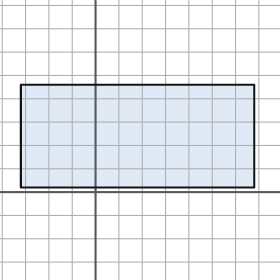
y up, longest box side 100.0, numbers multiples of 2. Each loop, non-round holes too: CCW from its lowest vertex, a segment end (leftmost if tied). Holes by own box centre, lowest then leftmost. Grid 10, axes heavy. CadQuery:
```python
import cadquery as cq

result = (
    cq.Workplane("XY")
    .moveTo(-32.0, 2.0)
    .lineTo(68.0, 2.0)
    .lineTo(68.0, 46.0)
    .lineTo(-32.0, 46.0)
    .close()
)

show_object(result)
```